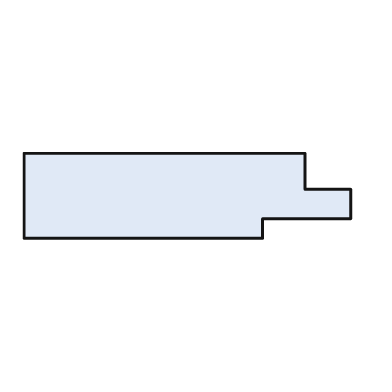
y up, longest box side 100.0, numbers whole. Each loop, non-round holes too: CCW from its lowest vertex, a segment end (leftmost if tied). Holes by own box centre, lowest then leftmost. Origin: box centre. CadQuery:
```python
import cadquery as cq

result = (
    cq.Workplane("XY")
    .moveTo(-50.0, -13.0)
    .lineTo(23.0, -13.0)
    .lineTo(23.0, -7.0)
    .lineTo(50.0, -7.0)
    .lineTo(50.0, 2.0)
    .lineTo(36.0, 2.0)
    .lineTo(36.0, 13.0)
    .lineTo(-50.0, 13.0)
    .close()
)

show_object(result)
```